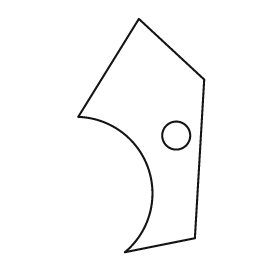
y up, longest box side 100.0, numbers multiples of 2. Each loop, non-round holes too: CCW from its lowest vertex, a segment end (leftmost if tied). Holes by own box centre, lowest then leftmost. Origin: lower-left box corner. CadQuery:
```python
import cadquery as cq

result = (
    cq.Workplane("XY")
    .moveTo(20.0, 0.0)
    .lineTo(50.0, 6.0)
    .lineTo(54.0, 74.0)
    .lineTo(26.0, 100.0)
    .lineTo(0.0, 58.0)
    .threePointArc((30.0, 36.0), (20.0, 0.0))
    .close()
    .moveTo(42.0, 50.0)
    .circle(6.0)
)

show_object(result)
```